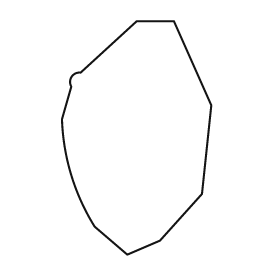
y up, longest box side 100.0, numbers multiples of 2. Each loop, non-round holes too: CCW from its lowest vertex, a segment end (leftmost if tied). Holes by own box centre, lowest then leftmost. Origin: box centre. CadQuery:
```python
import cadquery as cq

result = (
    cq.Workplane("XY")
    .moveTo(-4.0, -50.0)
    .lineTo(10.0, -44.0)
    .lineTo(28.0, -24.0)
    .lineTo(32.0, 14.0)
    .lineTo(16.0, 50.0)
    .lineTo(0.0, 50.0)
    .lineTo(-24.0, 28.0)
    .threePointArc((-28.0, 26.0), (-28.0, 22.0))
    .lineTo(-32.0, 8.0)
    .threePointArc((-28.0, -16.0), (-18.0, -38.0))
    .close()
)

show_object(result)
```